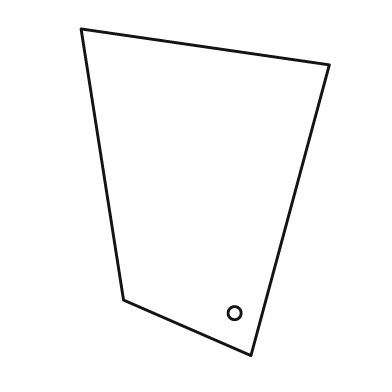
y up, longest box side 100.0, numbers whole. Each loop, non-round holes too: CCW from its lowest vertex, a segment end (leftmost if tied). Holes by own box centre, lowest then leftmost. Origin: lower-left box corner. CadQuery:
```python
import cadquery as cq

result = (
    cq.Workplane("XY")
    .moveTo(52.0, 0.0)
    .lineTo(76.0, 89.0)
    .lineTo(0.0, 100.0)
    .lineTo(13.0, 17.0)
    .close()
    .moveTo(47.0, 13.0)
    .circle(2.0)
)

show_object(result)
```